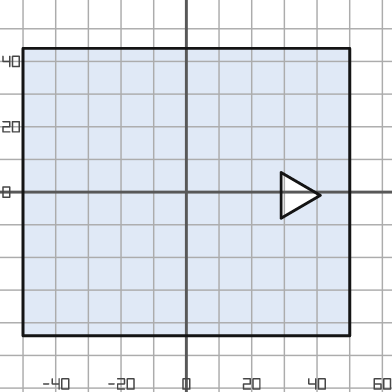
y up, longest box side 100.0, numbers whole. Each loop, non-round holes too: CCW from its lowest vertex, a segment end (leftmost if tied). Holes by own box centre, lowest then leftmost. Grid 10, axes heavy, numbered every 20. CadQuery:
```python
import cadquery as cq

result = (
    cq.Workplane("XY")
    .moveTo(-50.0, -44.0)
    .lineTo(50.0, -44.0)
    .lineTo(50.0, 44.0)
    .lineTo(-50.0, 44.0)
    .close()
    .moveTo(29.0, -8.0)
    .lineTo(41.0, -1.0)
    .lineTo(29.0, 6.0)
    .close()
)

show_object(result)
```